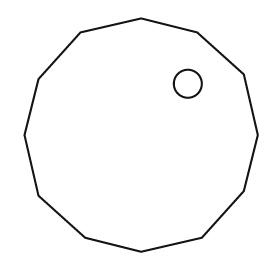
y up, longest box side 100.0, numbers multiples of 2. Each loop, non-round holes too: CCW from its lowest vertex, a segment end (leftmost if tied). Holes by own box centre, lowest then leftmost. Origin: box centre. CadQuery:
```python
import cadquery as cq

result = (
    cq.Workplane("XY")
    .moveTo(0.0, -50.0)
    .lineTo(26.0, -44.0)
    .lineTo(44.0, -24.0)
    .lineTo(50.0, 0.0)
    .lineTo(44.0, 26.0)
    .lineTo(24.0, 44.0)
    .lineTo(0.0, 50.0)
    .lineTo(-26.0, 44.0)
    .lineTo(-44.0, 24.0)
    .lineTo(-50.0, 0.0)
    .lineTo(-44.0, -26.0)
    .lineTo(-24.0, -44.0)
    .close()
    .moveTo(20.0, 22.0)
    .circle(6.0)
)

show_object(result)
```